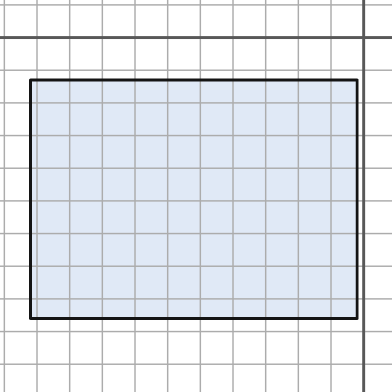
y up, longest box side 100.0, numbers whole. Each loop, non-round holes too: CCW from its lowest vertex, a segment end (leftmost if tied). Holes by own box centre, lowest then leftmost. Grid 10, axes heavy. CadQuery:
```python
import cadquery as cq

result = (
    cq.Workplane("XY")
    .moveTo(-102.0, -86.0)
    .lineTo(-2.0, -86.0)
    .lineTo(-2.0, -13.0)
    .lineTo(-102.0, -13.0)
    .close()
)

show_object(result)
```